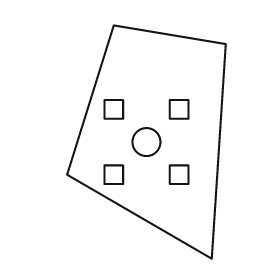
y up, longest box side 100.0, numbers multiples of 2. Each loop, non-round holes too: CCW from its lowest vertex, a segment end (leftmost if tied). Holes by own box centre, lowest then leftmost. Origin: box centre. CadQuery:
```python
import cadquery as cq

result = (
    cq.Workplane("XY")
    .moveTo(28.0, -50.0)
    .lineTo(34.0, 42.0)
    .lineTo(-14.0, 50.0)
    .lineTo(-34.0, -14.0)
    .close()
    .moveTo(-18.0, -18.0)
    .lineTo(-10.0, -18.0)
    .lineTo(-10.0, -10.0)
    .lineTo(-18.0, -10.0)
    .close()
    .moveTo(10.0, -18.0)
    .lineTo(18.0, -18.0)
    .lineTo(18.0, -10.0)
    .lineTo(10.0, -10.0)
    .close()
    .moveTo(0.0, 0.0)
    .circle(6.0)
    .moveTo(-18.0, 10.0)
    .lineTo(-10.0, 10.0)
    .lineTo(-10.0, 18.0)
    .lineTo(-18.0, 18.0)
    .close()
    .moveTo(10.0, 10.0)
    .lineTo(18.0, 10.0)
    .lineTo(18.0, 18.0)
    .lineTo(10.0, 18.0)
    .close()
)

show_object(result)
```